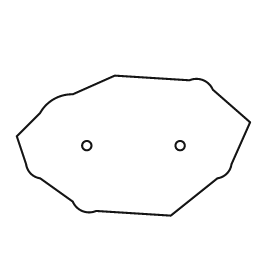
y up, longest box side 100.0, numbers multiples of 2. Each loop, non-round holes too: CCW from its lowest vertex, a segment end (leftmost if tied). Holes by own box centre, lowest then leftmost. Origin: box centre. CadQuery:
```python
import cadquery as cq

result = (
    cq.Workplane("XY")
    .moveTo(16.0, -30.0)
    .lineTo(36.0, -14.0)
    .threePointArc((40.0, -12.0), (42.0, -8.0))
    .lineTo(50.0, 10.0)
    .lineTo(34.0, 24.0)
    .threePointArc((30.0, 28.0), (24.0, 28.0))
    .lineTo(-8.0, 30.0)
    .lineTo(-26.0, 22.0)
    .threePointArc((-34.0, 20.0), (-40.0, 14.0))
    .lineTo(-50.0, 4.0)
    .lineTo(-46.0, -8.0)
    .threePointArc((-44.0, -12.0), (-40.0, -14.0))
    .lineTo(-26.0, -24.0)
    .threePointArc((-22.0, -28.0), (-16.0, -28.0))
    .close()
    .moveTo(-20.0, 0.0)
    .circle(2.0)
    .moveTo(20.0, 0.0)
    .circle(2.0)
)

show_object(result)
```